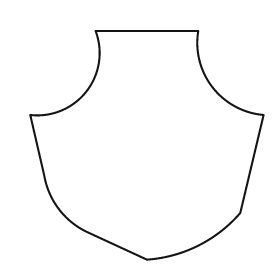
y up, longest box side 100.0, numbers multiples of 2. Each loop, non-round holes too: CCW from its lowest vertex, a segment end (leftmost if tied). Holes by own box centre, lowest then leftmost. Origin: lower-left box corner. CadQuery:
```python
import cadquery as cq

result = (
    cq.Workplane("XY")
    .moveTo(50.0, 0.0)
    .threePointArc((72.0, 6.0), (90.0, 20.0))
    .lineTo(100.0, 62.0)
    .threePointArc((78.0, 74.0), (72.0, 98.0))
    .lineTo(28.0, 98.0)
    .threePointArc((24.0, 72.0), (0.0, 62.0))
    .lineTo(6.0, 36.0)
    .threePointArc((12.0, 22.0), (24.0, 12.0))
    .close()
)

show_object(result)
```